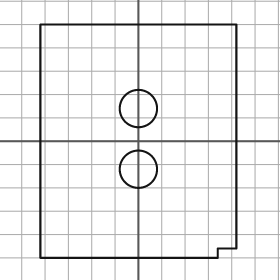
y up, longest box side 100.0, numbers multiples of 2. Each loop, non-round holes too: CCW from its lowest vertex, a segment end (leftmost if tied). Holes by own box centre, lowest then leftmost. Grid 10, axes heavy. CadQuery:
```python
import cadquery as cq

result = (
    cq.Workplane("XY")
    .moveTo(-42.0, -50.0)
    .lineTo(34.0, -50.0)
    .lineTo(34.0, -46.0)
    .lineTo(42.0, -46.0)
    .lineTo(42.0, 50.0)
    .lineTo(-42.0, 50.0)
    .close()
    .moveTo(0.0, -12.0)
    .circle(8.0)
    .moveTo(0.0, 14.0)
    .circle(8.0)
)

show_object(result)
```